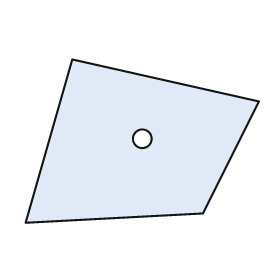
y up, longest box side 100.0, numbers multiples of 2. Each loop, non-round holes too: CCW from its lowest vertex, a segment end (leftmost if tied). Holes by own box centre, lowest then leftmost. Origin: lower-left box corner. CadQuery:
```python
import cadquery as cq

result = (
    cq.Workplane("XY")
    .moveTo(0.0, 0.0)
    .lineTo(76.0, 4.0)
    .lineTo(100.0, 52.0)
    .lineTo(20.0, 70.0)
    .close()
    .moveTo(50.0, 36.0)
    .circle(4.0)
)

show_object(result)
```